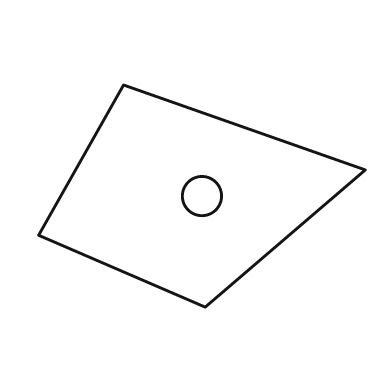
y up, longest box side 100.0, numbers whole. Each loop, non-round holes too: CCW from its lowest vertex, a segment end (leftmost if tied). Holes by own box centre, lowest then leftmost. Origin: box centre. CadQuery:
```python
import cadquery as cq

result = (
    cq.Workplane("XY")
    .moveTo(1.0, -34.0)
    .lineTo(50.0, 8.0)
    .lineTo(-24.0, 34.0)
    .lineTo(-50.0, -12.0)
    .close()
    .moveTo(0.0, 0.0)
    .circle(6.0)
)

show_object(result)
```